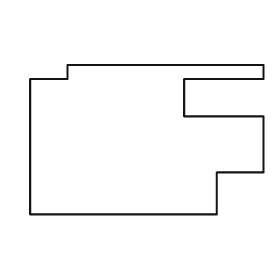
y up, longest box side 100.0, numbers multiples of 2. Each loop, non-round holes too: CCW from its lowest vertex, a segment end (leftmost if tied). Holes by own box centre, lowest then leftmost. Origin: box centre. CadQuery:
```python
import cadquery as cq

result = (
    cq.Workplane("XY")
    .moveTo(-50.0, -32.0)
    .lineTo(30.0, -32.0)
    .lineTo(30.0, -14.0)
    .lineTo(50.0, -14.0)
    .lineTo(50.0, 10.0)
    .lineTo(16.0, 10.0)
    .lineTo(16.0, 26.0)
    .lineTo(50.0, 26.0)
    .lineTo(50.0, 32.0)
    .lineTo(-34.0, 32.0)
    .lineTo(-34.0, 26.0)
    .lineTo(-50.0, 26.0)
    .close()
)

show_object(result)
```